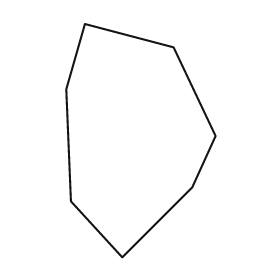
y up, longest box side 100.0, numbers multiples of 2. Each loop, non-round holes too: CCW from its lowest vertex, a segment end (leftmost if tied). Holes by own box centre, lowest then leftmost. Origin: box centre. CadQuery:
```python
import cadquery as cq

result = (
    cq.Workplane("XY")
    .moveTo(-8.0, -50.0)
    .lineTo(22.0, -20.0)
    .lineTo(32.0, 2.0)
    .lineTo(14.0, 40.0)
    .lineTo(-24.0, 50.0)
    .lineTo(-32.0, 22.0)
    .lineTo(-30.0, -26.0)
    .close()
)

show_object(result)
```